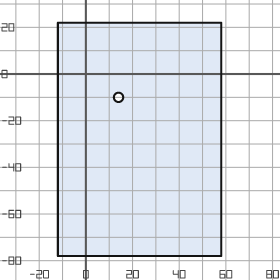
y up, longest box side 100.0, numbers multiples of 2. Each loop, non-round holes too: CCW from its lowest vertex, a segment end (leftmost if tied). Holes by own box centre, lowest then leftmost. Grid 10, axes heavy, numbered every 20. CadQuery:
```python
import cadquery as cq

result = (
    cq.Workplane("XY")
    .moveTo(-12.0, -78.0)
    .lineTo(58.0, -78.0)
    .lineTo(58.0, 22.0)
    .lineTo(-12.0, 22.0)
    .close()
    .moveTo(14.0, -10.0)
    .circle(2.0)
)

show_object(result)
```